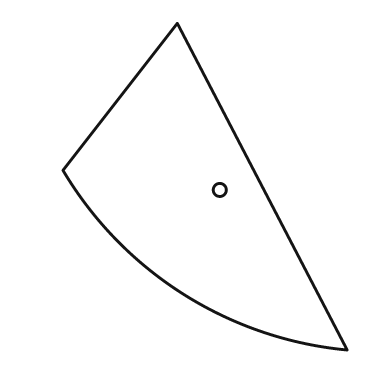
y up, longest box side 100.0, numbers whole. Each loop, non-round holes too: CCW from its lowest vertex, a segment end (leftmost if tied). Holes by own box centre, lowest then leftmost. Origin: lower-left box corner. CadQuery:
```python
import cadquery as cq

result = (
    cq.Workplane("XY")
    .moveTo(87.0, 0.0)
    .lineTo(35.0, 100.0)
    .lineTo(0.0, 55.0)
    .threePointArc((37.0, 17.0), (87.0, 0.0))
    .close()
    .moveTo(48.0, 49.0)
    .circle(2.0)
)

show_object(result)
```